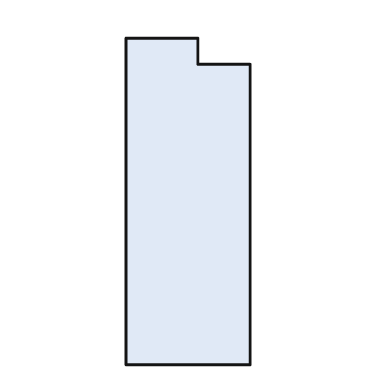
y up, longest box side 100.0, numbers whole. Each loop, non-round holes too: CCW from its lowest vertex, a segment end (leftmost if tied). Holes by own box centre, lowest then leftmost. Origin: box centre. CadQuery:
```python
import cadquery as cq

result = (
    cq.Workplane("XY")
    .moveTo(-19.0, -50.0)
    .lineTo(19.0, -50.0)
    .lineTo(19.0, 42.0)
    .lineTo(3.0, 42.0)
    .lineTo(3.0, 50.0)
    .lineTo(-19.0, 50.0)
    .close()
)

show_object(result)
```